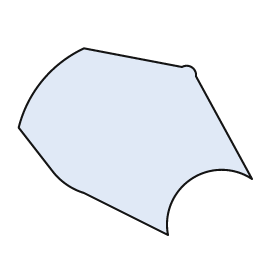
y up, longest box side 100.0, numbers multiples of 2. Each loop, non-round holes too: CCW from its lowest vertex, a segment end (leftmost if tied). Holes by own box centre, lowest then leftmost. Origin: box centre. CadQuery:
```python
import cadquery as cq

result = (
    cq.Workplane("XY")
    .moveTo(14.0, -40.0)
    .threePointArc((24.0, -16.0), (50.0, -16.0))
    .lineTo(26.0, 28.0)
    .threePointArc((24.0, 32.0), (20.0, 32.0))
    .lineTo(-22.0, 40.0)
    .threePointArc((-40.0, 26.0), (-50.0, 6.0))
    .lineTo(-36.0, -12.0)
    .threePointArc((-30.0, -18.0), (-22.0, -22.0))
    .close()
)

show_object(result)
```